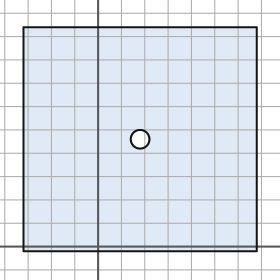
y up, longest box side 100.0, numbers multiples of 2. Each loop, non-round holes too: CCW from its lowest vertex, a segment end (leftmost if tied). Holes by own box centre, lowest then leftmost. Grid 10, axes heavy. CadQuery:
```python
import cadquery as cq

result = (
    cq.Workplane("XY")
    .moveTo(-32.0, -2.0)
    .lineTo(68.0, -2.0)
    .lineTo(68.0, 94.0)
    .lineTo(-32.0, 94.0)
    .close()
    .moveTo(18.0, 46.0)
    .circle(4.0)
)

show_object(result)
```